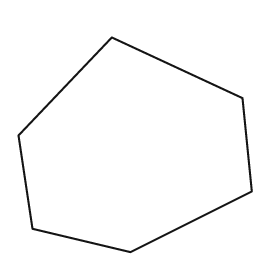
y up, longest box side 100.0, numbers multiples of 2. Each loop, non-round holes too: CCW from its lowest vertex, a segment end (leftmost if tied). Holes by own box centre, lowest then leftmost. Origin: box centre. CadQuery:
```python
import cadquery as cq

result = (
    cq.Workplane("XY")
    .moveTo(-2.0, -46.0)
    .lineTo(50.0, -20.0)
    .lineTo(46.0, 20.0)
    .lineTo(-10.0, 46.0)
    .lineTo(-50.0, 4.0)
    .lineTo(-44.0, -36.0)
    .close()
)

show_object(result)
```